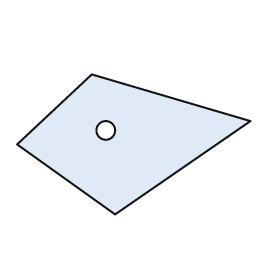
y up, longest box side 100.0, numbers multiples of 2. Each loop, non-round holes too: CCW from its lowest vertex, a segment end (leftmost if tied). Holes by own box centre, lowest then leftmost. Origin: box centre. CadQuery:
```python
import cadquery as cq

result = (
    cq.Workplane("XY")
    .moveTo(-8.0, -30.0)
    .lineTo(50.0, 10.0)
    .lineTo(-18.0, 30.0)
    .lineTo(-50.0, 0.0)
    .close()
    .moveTo(-12.0, 6.0)
    .circle(4.0)
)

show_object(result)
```